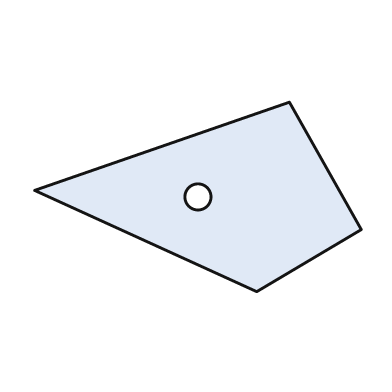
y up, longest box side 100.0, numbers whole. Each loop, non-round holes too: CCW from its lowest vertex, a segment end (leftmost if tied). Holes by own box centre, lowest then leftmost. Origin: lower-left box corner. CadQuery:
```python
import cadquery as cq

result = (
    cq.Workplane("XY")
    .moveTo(68.0, 0.0)
    .lineTo(100.0, 19.0)
    .lineTo(78.0, 58.0)
    .lineTo(0.0, 31.0)
    .close()
    .moveTo(50.0, 29.0)
    .circle(4.0)
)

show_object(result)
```